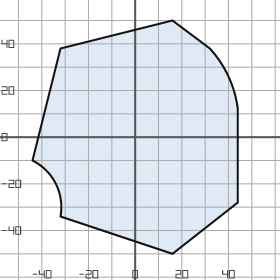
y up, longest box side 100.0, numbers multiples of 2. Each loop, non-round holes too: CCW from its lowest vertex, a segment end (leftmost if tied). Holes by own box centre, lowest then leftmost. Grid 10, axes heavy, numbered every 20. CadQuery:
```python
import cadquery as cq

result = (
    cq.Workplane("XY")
    .moveTo(16.0, -50.0)
    .lineTo(44.0, -28.0)
    .lineTo(44.0, 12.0)
    .threePointArc((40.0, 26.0), (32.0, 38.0))
    .lineTo(16.0, 50.0)
    .lineTo(-32.0, 38.0)
    .lineTo(-44.0, -10.0)
    .threePointArc((-34.0, -20.0), (-32.0, -34.0))
    .close()
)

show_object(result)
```